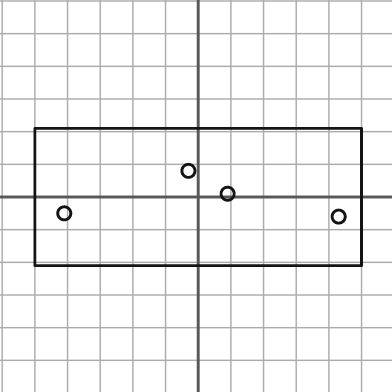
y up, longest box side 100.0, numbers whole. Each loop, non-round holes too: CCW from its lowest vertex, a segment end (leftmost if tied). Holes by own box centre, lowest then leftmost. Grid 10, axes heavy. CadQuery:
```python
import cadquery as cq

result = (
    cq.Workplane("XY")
    .moveTo(-50.0, -21.0)
    .lineTo(50.0, -21.0)
    .lineTo(50.0, 21.0)
    .lineTo(-50.0, 21.0)
    .close()
    .moveTo(43.0, -6.0)
    .circle(2.0)
    .moveTo(-41.0, -5.0)
    .circle(2.0)
    .moveTo(9.0, 1.0)
    .circle(2.0)
    .moveTo(-3.0, 8.0)
    .circle(2.0)
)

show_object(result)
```